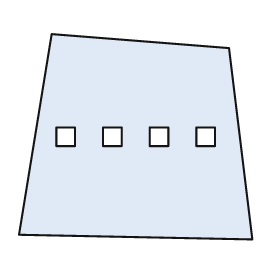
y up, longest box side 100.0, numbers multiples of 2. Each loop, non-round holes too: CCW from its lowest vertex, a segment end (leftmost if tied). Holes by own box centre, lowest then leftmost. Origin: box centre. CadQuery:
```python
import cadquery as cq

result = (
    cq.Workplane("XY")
    .moveTo(50.0, -44.0)
    .lineTo(40.0, 38.0)
    .lineTo(-36.0, 44.0)
    .lineTo(-50.0, -42.0)
    .close()
    .moveTo(-34.0, -4.0)
    .lineTo(-26.0, -4.0)
    .lineTo(-26.0, 4.0)
    .lineTo(-34.0, 4.0)
    .close()
    .moveTo(-14.0, -4.0)
    .lineTo(-6.0, -4.0)
    .lineTo(-6.0, 4.0)
    .lineTo(-14.0, 4.0)
    .close()
    .moveTo(6.0, -4.0)
    .lineTo(14.0, -4.0)
    .lineTo(14.0, 4.0)
    .lineTo(6.0, 4.0)
    .close()
    .moveTo(26.0, -4.0)
    .lineTo(34.0, -4.0)
    .lineTo(34.0, 4.0)
    .lineTo(26.0, 4.0)
    .close()
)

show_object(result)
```